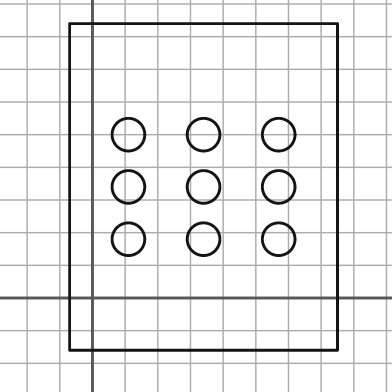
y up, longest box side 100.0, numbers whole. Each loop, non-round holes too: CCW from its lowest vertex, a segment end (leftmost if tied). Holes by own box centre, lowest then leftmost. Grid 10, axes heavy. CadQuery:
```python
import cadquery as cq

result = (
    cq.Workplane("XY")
    .moveTo(-7.0, -16.0)
    .lineTo(75.0, -16.0)
    .lineTo(75.0, 84.0)
    .lineTo(-7.0, 84.0)
    .close()
    .moveTo(11.0, 18.0)
    .circle(5.0)
    .moveTo(34.0, 18.0)
    .circle(5.0)
    .moveTo(57.0, 18.0)
    .circle(5.0)
    .moveTo(11.0, 34.0)
    .circle(5.0)
    .moveTo(34.0, 34.0)
    .circle(5.0)
    .moveTo(57.0, 34.0)
    .circle(5.0)
    .moveTo(11.0, 50.0)
    .circle(5.0)
    .moveTo(34.0, 50.0)
    .circle(5.0)
    .moveTo(57.0, 50.0)
    .circle(5.0)
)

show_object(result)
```